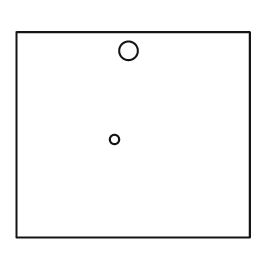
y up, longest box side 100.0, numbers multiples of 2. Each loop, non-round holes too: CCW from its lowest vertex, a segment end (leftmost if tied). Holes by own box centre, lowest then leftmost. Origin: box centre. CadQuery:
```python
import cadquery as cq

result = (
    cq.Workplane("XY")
    .moveTo(-50.0, -44.0)
    .lineTo(50.0, -44.0)
    .lineTo(50.0, 44.0)
    .lineTo(-50.0, 44.0)
    .close()
    .moveTo(-8.0, -2.0)
    .circle(2.0)
    .moveTo(-2.0, 36.0)
    .circle(4.0)
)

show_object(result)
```